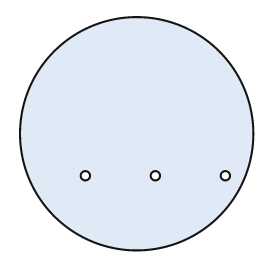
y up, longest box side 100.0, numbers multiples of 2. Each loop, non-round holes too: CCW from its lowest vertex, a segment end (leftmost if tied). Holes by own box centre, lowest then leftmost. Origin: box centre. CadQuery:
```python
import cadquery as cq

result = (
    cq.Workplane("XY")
    .moveTo(0.0, 0.0)
    .circle(50.0)
    .moveTo(-22.0, -18.0)
    .circle(2.0)
    .moveTo(8.0, -18.0)
    .circle(2.0)
    .moveTo(38.0, -18.0)
    .circle(2.0)
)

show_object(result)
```